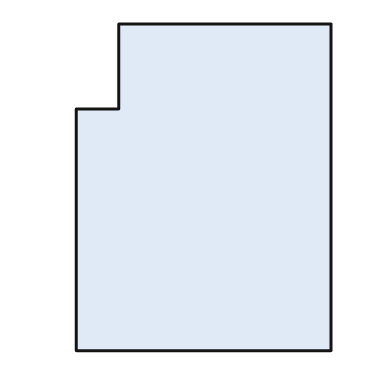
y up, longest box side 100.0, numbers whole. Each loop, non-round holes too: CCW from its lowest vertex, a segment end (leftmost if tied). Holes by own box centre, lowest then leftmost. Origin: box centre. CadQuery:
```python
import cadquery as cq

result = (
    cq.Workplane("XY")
    .moveTo(-39.0, -50.0)
    .lineTo(39.0, -50.0)
    .lineTo(39.0, 50.0)
    .lineTo(-26.0, 50.0)
    .lineTo(-26.0, 24.0)
    .lineTo(-39.0, 24.0)
    .close()
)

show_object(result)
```